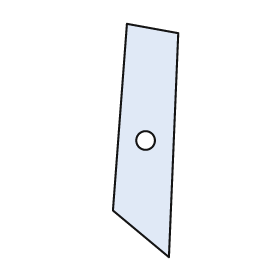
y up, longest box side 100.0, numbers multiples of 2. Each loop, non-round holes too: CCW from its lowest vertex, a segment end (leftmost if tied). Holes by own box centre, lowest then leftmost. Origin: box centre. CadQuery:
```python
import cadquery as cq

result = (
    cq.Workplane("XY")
    .moveTo(10.0, -50.0)
    .lineTo(14.0, 46.0)
    .lineTo(-8.0, 50.0)
    .lineTo(-14.0, -30.0)
    .close()
    .moveTo(0.0, 0.0)
    .circle(4.0)
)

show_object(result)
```